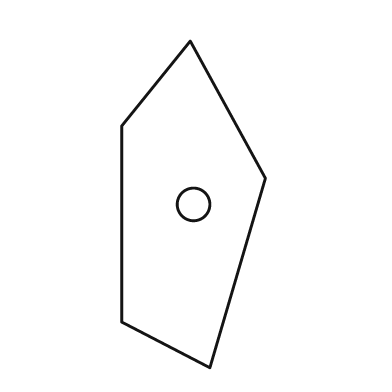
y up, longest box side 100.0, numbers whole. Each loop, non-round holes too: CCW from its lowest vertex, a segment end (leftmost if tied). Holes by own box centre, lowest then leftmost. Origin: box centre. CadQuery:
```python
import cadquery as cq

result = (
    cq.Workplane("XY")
    .moveTo(5.0, -50.0)
    .lineTo(22.0, 8.0)
    .lineTo(-1.0, 50.0)
    .lineTo(-22.0, 24.0)
    .lineTo(-22.0, -36.0)
    .close()
    .moveTo(0.0, 0.0)
    .circle(5.0)
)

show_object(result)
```